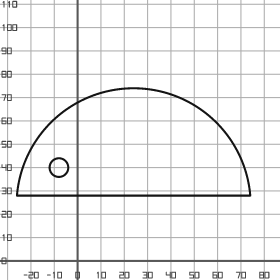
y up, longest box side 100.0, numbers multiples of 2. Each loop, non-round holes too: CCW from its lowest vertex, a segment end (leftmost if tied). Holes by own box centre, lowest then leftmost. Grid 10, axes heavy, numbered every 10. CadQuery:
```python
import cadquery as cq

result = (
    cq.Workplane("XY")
    .moveTo(-26.0, 28.0)
    .lineTo(74.0, 28.0)
    .threePointArc((24.0, 74.0), (-26.0, 28.0))
    .close()
    .moveTo(-8.0, 40.0)
    .circle(4.0)
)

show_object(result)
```